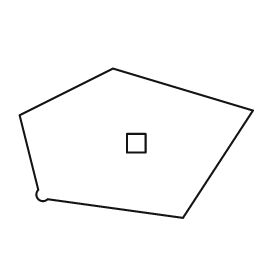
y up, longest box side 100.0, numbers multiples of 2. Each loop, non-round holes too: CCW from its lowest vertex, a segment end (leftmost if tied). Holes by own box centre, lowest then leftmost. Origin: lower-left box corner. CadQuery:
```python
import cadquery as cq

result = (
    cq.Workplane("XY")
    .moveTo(70.0, 0.0)
    .lineTo(100.0, 46.0)
    .lineTo(40.0, 64.0)
    .lineTo(0.0, 44.0)
    .lineTo(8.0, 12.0)
    .threePointArc((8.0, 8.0), (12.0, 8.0))
    .close()
    .moveTo(46.0, 28.0)
    .lineTo(54.0, 28.0)
    .lineTo(54.0, 36.0)
    .lineTo(46.0, 36.0)
    .close()
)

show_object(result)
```